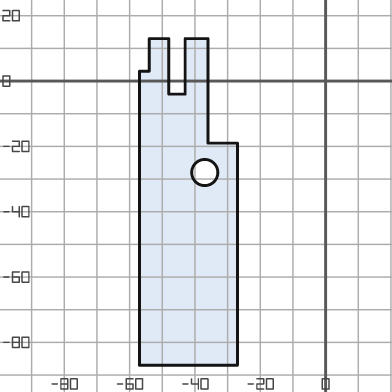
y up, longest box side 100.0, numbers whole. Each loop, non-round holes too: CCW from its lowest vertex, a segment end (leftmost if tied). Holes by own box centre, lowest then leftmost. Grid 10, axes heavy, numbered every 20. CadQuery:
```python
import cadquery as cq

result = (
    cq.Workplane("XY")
    .moveTo(-57.0, -87.0)
    .lineTo(-27.0, -87.0)
    .lineTo(-27.0, -19.0)
    .lineTo(-36.0, -19.0)
    .lineTo(-36.0, 13.0)
    .lineTo(-43.0, 13.0)
    .lineTo(-43.0, -4.0)
    .lineTo(-48.0, -4.0)
    .lineTo(-48.0, 13.0)
    .lineTo(-54.0, 13.0)
    .lineTo(-54.0, 3.0)
    .lineTo(-57.0, 3.0)
    .close()
    .moveTo(-37.0, -28.0)
    .circle(4.0)
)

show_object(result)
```